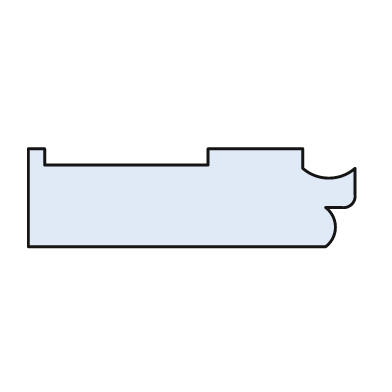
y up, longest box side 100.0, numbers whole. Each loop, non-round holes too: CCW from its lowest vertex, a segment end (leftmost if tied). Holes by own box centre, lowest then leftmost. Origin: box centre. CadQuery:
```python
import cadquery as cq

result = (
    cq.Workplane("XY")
    .moveTo(-50.0, -15.0)
    .lineTo(41.0, -15.0)
    .threePointArc((44.0, -9.0), (41.0, -3.0))
    .lineTo(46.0, -3.0)
    .threePointArc((49.0, -2.0), (50.0, 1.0))
    .lineTo(50.0, 9.0)
    .threePointArc((42.0, 6.0), (34.0, 9.0))
    .lineTo(34.0, 15.0)
    .lineTo(5.0, 15.0)
    .lineTo(5.0, 10.0)
    .lineTo(-45.0, 10.0)
    .lineTo(-45.0, 15.0)
    .lineTo(-50.0, 15.0)
    .close()
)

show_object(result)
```